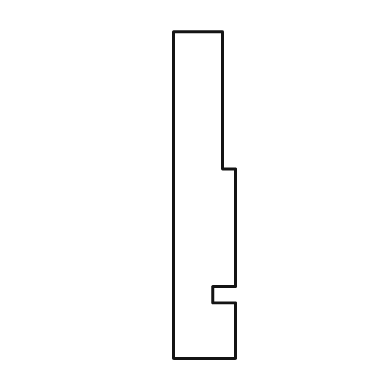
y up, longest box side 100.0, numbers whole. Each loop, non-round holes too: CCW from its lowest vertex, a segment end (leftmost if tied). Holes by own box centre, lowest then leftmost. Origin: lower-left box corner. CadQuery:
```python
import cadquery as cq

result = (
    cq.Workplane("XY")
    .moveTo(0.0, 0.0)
    .lineTo(19.0, 0.0)
    .lineTo(19.0, 17.0)
    .lineTo(12.0, 17.0)
    .lineTo(12.0, 22.0)
    .lineTo(19.0, 22.0)
    .lineTo(19.0, 58.0)
    .lineTo(15.0, 58.0)
    .lineTo(15.0, 100.0)
    .lineTo(0.0, 100.0)
    .close()
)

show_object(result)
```